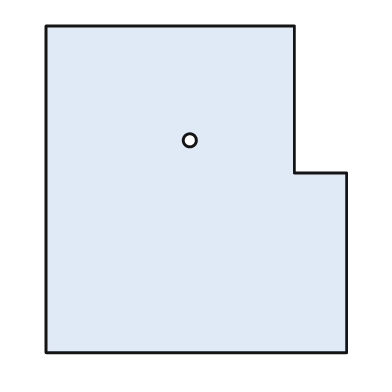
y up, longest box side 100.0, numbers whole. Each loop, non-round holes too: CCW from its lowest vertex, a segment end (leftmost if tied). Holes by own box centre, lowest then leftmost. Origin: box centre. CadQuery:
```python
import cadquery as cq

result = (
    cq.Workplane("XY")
    .moveTo(-46.0, -50.0)
    .lineTo(46.0, -50.0)
    .lineTo(46.0, 5.0)
    .lineTo(30.0, 5.0)
    .lineTo(30.0, 50.0)
    .lineTo(-46.0, 50.0)
    .close()
    .moveTo(-2.0, 15.0)
    .circle(2.0)
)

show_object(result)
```